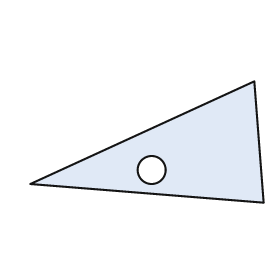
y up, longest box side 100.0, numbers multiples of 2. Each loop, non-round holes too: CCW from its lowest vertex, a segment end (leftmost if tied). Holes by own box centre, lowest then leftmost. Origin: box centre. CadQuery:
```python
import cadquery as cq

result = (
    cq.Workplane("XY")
    .moveTo(50.0, -26.0)
    .lineTo(46.0, 26.0)
    .lineTo(-50.0, -18.0)
    .close()
    .moveTo(2.0, -12.0)
    .circle(6.0)
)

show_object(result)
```